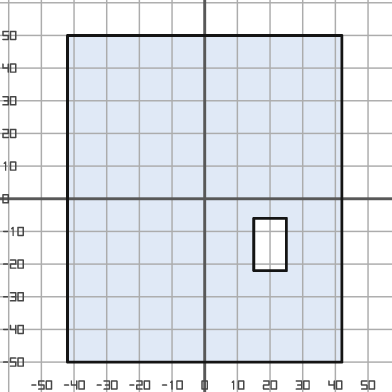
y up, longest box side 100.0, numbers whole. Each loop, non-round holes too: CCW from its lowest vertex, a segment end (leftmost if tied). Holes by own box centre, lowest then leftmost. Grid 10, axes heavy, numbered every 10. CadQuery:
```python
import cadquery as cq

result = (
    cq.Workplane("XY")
    .moveTo(-42.0, -50.0)
    .lineTo(42.0, -50.0)
    .lineTo(42.0, 50.0)
    .lineTo(-42.0, 50.0)
    .close()
    .moveTo(15.0, -22.0)
    .lineTo(25.0, -22.0)
    .lineTo(25.0, -6.0)
    .lineTo(15.0, -6.0)
    .close()
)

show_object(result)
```